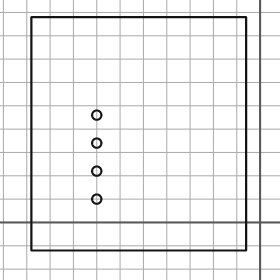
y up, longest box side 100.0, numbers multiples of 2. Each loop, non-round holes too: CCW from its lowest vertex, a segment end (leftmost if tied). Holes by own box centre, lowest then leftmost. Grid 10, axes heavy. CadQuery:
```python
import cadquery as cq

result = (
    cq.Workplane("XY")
    .moveTo(-98.0, -12.0)
    .lineTo(-6.0, -12.0)
    .lineTo(-6.0, 88.0)
    .lineTo(-98.0, 88.0)
    .close()
    .moveTo(-70.0, 10.0)
    .circle(2.0)
    .moveTo(-70.0, 22.0)
    .circle(2.0)
    .moveTo(-70.0, 34.0)
    .circle(2.0)
    .moveTo(-70.0, 46.0)
    .circle(2.0)
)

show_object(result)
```